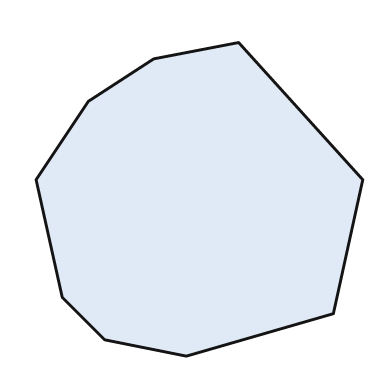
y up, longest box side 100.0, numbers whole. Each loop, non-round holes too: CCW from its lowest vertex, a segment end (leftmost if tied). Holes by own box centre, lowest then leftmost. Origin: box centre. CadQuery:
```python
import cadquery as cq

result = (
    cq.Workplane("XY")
    .moveTo(-4.0, -48.0)
    .lineTo(41.0, -35.0)
    .lineTo(50.0, 6.0)
    .lineTo(12.0, 48.0)
    .lineTo(-14.0, 43.0)
    .lineTo(-34.0, 30.0)
    .lineTo(-50.0, 6.0)
    .lineTo(-42.0, -30.0)
    .lineTo(-29.0, -43.0)
    .close()
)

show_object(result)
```